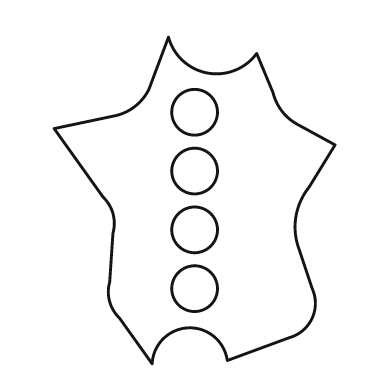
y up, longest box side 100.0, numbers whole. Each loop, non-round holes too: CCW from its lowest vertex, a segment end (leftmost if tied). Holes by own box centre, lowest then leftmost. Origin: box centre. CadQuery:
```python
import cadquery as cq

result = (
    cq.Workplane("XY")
    .moveTo(-13.0, -50.0)
    .threePointArc((-2.0, -39.0), (10.0, -49.0))
    .lineTo(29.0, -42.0)
    .threePointArc((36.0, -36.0), (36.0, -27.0))
    .lineTo(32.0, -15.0)
    .threePointArc((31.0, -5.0), (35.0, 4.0))
    .lineTo(43.0, 17.0)
    .lineTo(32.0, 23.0)
    .threePointArc((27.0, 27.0), (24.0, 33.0))
    .lineTo(19.0, 45.0)
    .threePointArc((4.0, 39.0), (-8.0, 50.0))
    .lineTo(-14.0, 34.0)
    .threePointArc((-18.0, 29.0), (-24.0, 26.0))
    .lineTo(-43.0, 22.0)
    .lineTo(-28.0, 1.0)
    .threePointArc((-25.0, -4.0), (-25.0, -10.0))
    .lineTo(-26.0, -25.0)
    .threePointArc((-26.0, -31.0), (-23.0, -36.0))
    .close()
    .moveTo(0.0, -27.0)
    .circle(7.0)
    .moveTo(0.0, -9.0)
    .circle(7.0)
    .moveTo(0.0, 9.0)
    .circle(7.0)
    .moveTo(0.0, 27.0)
    .circle(7.0)
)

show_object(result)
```